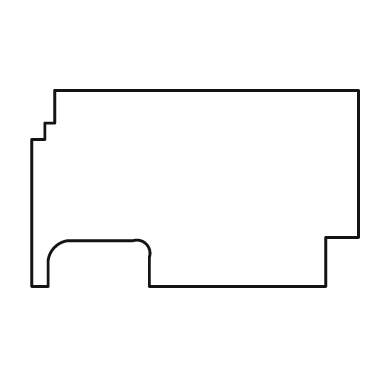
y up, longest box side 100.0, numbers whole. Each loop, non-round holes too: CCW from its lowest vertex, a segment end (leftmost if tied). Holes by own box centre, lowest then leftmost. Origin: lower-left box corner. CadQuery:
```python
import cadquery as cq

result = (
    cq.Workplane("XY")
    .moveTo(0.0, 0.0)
    .lineTo(5.0, 0.0)
    .lineTo(5.0, 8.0)
    .threePointArc((7.0, 12.0), (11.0, 14.0))
    .lineTo(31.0, 14.0)
    .threePointArc((35.0, 13.0), (36.0, 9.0))
    .lineTo(36.0, 0.0)
    .lineTo(90.0, 0.0)
    .lineTo(90.0, 15.0)
    .lineTo(100.0, 15.0)
    .lineTo(100.0, 60.0)
    .lineTo(7.0, 60.0)
    .lineTo(7.0, 50.0)
    .lineTo(4.0, 50.0)
    .lineTo(4.0, 45.0)
    .lineTo(0.0, 45.0)
    .close()
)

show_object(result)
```